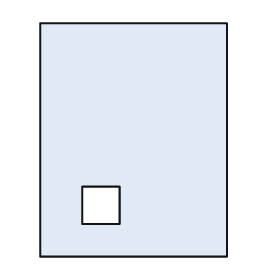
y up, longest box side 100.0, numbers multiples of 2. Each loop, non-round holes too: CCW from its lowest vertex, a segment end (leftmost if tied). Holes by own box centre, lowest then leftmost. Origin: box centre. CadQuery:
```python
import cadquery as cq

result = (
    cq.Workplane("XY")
    .moveTo(-40.0, -50.0)
    .lineTo(40.0, -50.0)
    .lineTo(40.0, 50.0)
    .lineTo(-40.0, 50.0)
    .close()
    .moveTo(-22.0, -36.0)
    .lineTo(-6.0, -36.0)
    .lineTo(-6.0, -20.0)
    .lineTo(-22.0, -20.0)
    .close()
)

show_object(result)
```